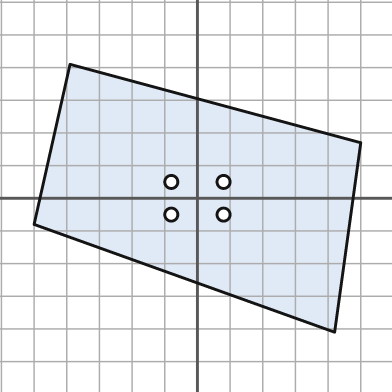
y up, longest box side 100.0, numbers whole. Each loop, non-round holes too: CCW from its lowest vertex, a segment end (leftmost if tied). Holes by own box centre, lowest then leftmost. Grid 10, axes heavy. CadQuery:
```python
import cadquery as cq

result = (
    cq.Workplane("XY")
    .moveTo(42.0, -41.0)
    .lineTo(50.0, 17.0)
    .lineTo(-39.0, 41.0)
    .lineTo(-50.0, -8.0)
    .close()
    .moveTo(-8.0, -5.0)
    .circle(2.0)
    .moveTo(8.0, -5.0)
    .circle(2.0)
    .moveTo(-8.0, 5.0)
    .circle(2.0)
    .moveTo(8.0, 5.0)
    .circle(2.0)
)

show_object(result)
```